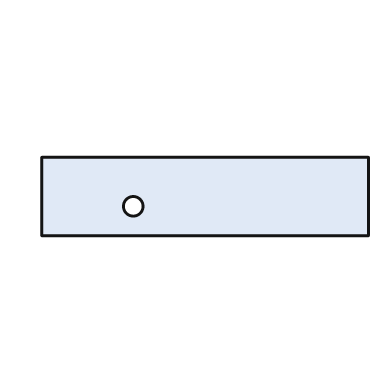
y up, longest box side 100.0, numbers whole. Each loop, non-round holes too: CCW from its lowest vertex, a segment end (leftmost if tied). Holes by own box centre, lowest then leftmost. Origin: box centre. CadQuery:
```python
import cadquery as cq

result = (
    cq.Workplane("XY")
    .moveTo(-50.0, -12.0)
    .lineTo(50.0, -12.0)
    .lineTo(50.0, 12.0)
    .lineTo(-50.0, 12.0)
    .close()
    .moveTo(-22.0, -3.0)
    .circle(3.0)
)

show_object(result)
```